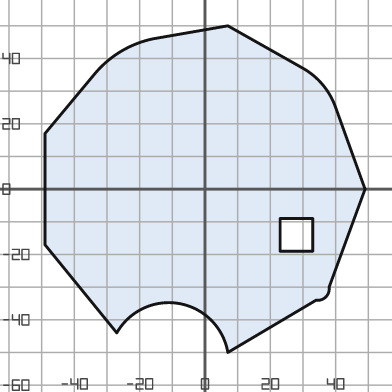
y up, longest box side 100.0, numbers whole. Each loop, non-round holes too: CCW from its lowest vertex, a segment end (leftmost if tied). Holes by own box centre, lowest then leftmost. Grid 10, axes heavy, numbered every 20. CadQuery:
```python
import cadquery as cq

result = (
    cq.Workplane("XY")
    .moveTo(7.0, -50.0)
    .lineTo(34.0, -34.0)
    .threePointArc((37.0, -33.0), (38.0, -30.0))
    .lineTo(49.0, 0.0)
    .lineTo(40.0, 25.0)
    .threePointArc((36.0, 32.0), (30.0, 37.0))
    .lineTo(7.0, 50.0)
    .lineTo(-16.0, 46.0)
    .threePointArc((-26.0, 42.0), (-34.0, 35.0))
    .lineTo(-49.0, 17.0)
    .lineTo(-49.0, -17.0)
    .lineTo(-27.0, -44.0)
    .threePointArc((-8.0, -35.0), (7.0, -50.0))
    .close()
    .moveTo(23.0, -19.0)
    .lineTo(33.0, -19.0)
    .lineTo(33.0, -9.0)
    .lineTo(23.0, -9.0)
    .close()
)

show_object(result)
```